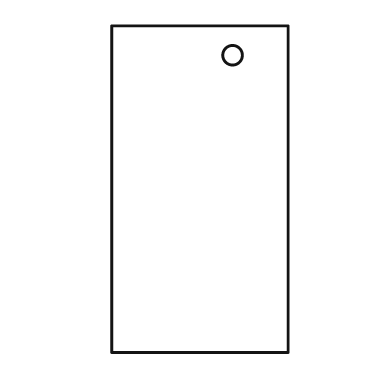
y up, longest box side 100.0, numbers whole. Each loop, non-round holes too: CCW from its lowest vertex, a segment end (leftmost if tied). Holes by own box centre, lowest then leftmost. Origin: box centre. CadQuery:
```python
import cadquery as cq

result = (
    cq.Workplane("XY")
    .moveTo(-27.0, -50.0)
    .lineTo(27.0, -50.0)
    .lineTo(27.0, 50.0)
    .lineTo(-27.0, 50.0)
    .close()
    .moveTo(10.0, 41.0)
    .circle(3.0)
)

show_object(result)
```